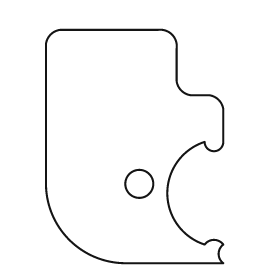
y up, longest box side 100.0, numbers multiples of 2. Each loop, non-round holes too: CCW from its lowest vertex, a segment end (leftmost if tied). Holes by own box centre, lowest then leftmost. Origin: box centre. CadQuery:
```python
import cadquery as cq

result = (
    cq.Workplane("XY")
    .moveTo(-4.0, -50.0)
    .lineTo(38.0, -50.0)
    .threePointArc((36.0, -46.0), (38.0, -42.0))
    .threePointArc((34.0, -40.0), (30.0, -42.0))
    .threePointArc((14.0, -20.0), (30.0, 2.0))
    .threePointArc((34.0, -2.0), (38.0, 2.0))
    .lineTo(38.0, 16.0)
    .threePointArc((36.0, 20.0), (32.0, 22.0))
    .lineTo(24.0, 22.0)
    .threePointArc((20.0, 24.0), (18.0, 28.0))
    .lineTo(18.0, 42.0)
    .threePointArc((16.0, 48.0), (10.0, 50.0))
    .lineTo(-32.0, 50.0)
    .threePointArc((-36.0, 48.0), (-38.0, 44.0))
    .lineTo(-38.0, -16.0)
    .threePointArc((-28.0, -40.0), (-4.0, -50.0))
    .close()
    .moveTo(2.0, -16.0)
    .circle(6.0)
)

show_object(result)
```